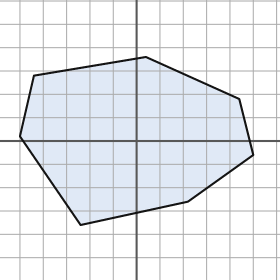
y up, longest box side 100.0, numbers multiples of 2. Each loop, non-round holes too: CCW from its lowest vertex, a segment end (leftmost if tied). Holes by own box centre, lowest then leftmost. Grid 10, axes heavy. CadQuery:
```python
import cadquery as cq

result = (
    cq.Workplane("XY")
    .moveTo(-24.0, -36.0)
    .lineTo(22.0, -26.0)
    .lineTo(50.0, -6.0)
    .lineTo(44.0, 18.0)
    .lineTo(4.0, 36.0)
    .lineTo(-44.0, 28.0)
    .lineTo(-50.0, 2.0)
    .close()
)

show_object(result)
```